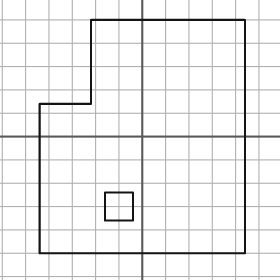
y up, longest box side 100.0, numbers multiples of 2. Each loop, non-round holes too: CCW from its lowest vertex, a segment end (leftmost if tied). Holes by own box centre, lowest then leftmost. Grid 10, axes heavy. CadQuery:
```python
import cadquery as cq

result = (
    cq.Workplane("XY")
    .moveTo(-44.0, -50.0)
    .lineTo(44.0, -50.0)
    .lineTo(44.0, 50.0)
    .lineTo(-22.0, 50.0)
    .lineTo(-22.0, 14.0)
    .lineTo(-44.0, 14.0)
    .close()
    .moveTo(-16.0, -36.0)
    .lineTo(-4.0, -36.0)
    .lineTo(-4.0, -24.0)
    .lineTo(-16.0, -24.0)
    .close()
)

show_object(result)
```